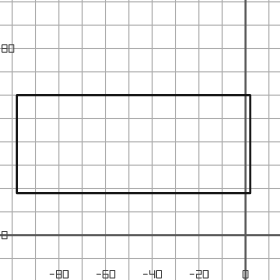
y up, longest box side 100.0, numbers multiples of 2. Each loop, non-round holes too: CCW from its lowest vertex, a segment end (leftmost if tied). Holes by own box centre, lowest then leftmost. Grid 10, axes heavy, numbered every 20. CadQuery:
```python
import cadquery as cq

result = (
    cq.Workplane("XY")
    .moveTo(-98.0, 18.0)
    .lineTo(2.0, 18.0)
    .lineTo(2.0, 60.0)
    .lineTo(-98.0, 60.0)
    .close()
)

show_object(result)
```